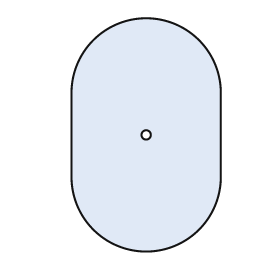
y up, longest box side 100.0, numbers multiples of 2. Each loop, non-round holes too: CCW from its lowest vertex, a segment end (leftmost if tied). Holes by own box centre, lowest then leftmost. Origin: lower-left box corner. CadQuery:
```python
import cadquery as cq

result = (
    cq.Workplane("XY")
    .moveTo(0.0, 32.0)
    .threePointArc((32.0, 0.0), (64.0, 32.0))
    .lineTo(64.0, 68.0)
    .threePointArc((32.0, 100.0), (0.0, 68.0))
    .close()
    .moveTo(32.0, 50.0)
    .circle(2.0)
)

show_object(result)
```